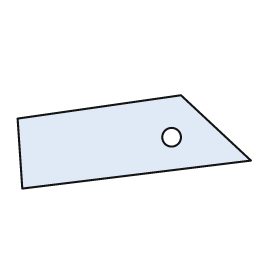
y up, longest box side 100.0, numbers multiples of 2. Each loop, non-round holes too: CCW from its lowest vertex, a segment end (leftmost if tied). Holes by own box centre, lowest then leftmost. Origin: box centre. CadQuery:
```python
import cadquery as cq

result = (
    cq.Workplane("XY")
    .moveTo(-48.0, -20.0)
    .lineTo(50.0, -8.0)
    .lineTo(20.0, 20.0)
    .lineTo(-50.0, 10.0)
    .close()
    .moveTo(16.0, 2.0)
    .circle(4.0)
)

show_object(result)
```